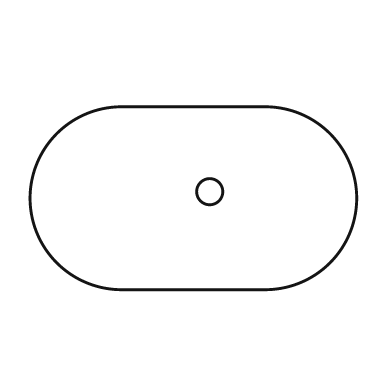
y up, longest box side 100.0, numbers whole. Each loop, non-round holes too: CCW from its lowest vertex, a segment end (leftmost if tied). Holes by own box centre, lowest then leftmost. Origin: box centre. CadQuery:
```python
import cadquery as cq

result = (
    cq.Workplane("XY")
    .moveTo(-22.0, -28.0)
    .lineTo(22.0, -28.0)
    .threePointArc((50.0, 0.0), (22.0, 28.0))
    .lineTo(-22.0, 28.0)
    .threePointArc((-50.0, 0.0), (-22.0, -28.0))
    .close()
    .moveTo(5.0, 2.0)
    .circle(4.0)
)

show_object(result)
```